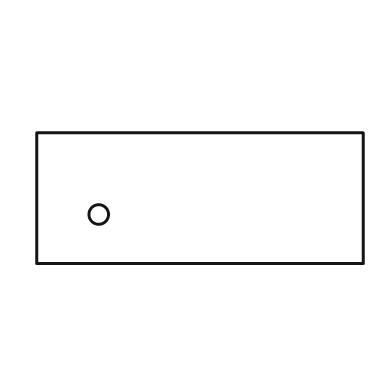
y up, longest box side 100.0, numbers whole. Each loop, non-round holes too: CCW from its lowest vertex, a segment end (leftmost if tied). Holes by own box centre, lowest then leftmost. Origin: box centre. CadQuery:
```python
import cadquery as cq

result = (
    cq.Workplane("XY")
    .moveTo(-50.0, -20.0)
    .lineTo(50.0, -20.0)
    .lineTo(50.0, 20.0)
    .lineTo(-50.0, 20.0)
    .close()
    .moveTo(-31.0, -5.0)
    .circle(3.0)
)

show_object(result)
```